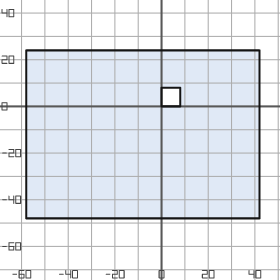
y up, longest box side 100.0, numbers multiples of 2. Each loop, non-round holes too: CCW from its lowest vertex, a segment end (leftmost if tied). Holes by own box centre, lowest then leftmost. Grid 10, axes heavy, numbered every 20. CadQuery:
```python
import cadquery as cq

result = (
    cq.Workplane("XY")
    .moveTo(-58.0, -48.0)
    .lineTo(42.0, -48.0)
    .lineTo(42.0, 24.0)
    .lineTo(-58.0, 24.0)
    .close()
    .moveTo(0.0, 0.0)
    .lineTo(8.0, 0.0)
    .lineTo(8.0, 8.0)
    .lineTo(0.0, 8.0)
    .close()
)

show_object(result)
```